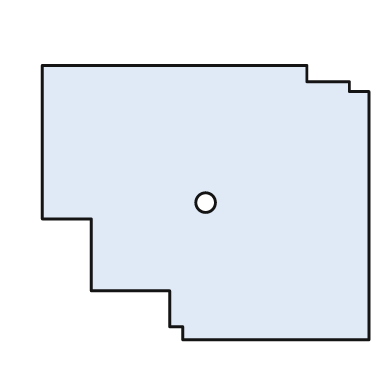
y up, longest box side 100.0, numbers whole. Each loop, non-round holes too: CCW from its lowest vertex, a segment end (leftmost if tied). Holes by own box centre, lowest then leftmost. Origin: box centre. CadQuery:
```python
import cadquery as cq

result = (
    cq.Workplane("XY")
    .moveTo(-7.0, -42.0)
    .lineTo(50.0, -42.0)
    .lineTo(50.0, 34.0)
    .lineTo(44.0, 34.0)
    .lineTo(44.0, 37.0)
    .lineTo(31.0, 37.0)
    .lineTo(31.0, 42.0)
    .lineTo(-50.0, 42.0)
    .lineTo(-50.0, -5.0)
    .lineTo(-35.0, -5.0)
    .lineTo(-35.0, -27.0)
    .lineTo(-11.0, -27.0)
    .lineTo(-11.0, -38.0)
    .lineTo(-7.0, -38.0)
    .close()
    .moveTo(0.0, 0.0)
    .circle(3.0)
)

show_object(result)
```